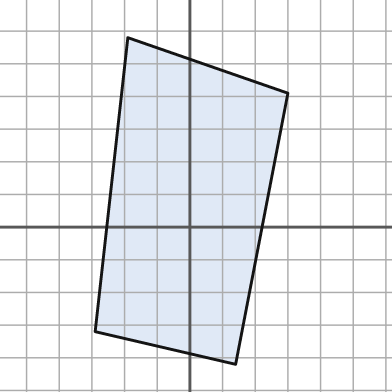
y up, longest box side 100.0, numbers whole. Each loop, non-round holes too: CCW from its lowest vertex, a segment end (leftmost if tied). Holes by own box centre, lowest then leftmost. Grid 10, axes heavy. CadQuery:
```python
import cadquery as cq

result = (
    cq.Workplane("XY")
    .moveTo(14.0, -42.0)
    .lineTo(30.0, 41.0)
    .lineTo(-19.0, 58.0)
    .lineTo(-29.0, -32.0)
    .close()
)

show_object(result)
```